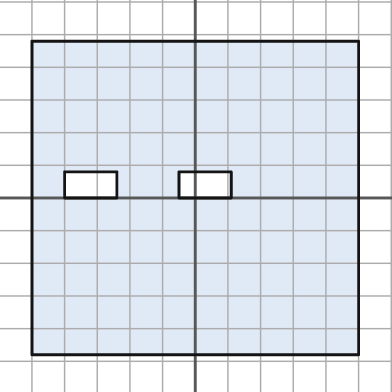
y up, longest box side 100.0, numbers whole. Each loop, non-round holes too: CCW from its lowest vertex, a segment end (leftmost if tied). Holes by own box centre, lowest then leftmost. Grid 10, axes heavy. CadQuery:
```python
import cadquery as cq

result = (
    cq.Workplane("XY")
    .moveTo(-50.0, -48.0)
    .lineTo(50.0, -48.0)
    .lineTo(50.0, 48.0)
    .lineTo(-50.0, 48.0)
    .close()
    .moveTo(-40.0, 0.0)
    .lineTo(-24.0, 0.0)
    .lineTo(-24.0, 8.0)
    .lineTo(-40.0, 8.0)
    .close()
    .moveTo(-5.0, 0.0)
    .lineTo(11.0, 0.0)
    .lineTo(11.0, 8.0)
    .lineTo(-5.0, 8.0)
    .close()
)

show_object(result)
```